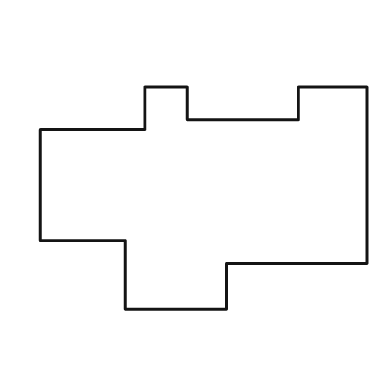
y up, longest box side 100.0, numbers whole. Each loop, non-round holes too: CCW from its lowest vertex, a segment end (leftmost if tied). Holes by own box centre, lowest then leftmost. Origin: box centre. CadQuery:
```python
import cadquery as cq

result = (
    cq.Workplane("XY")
    .moveTo(-24.0, -34.0)
    .lineTo(7.0, -34.0)
    .lineTo(7.0, -20.0)
    .lineTo(50.0, -20.0)
    .lineTo(50.0, 34.0)
    .lineTo(29.0, 34.0)
    .lineTo(29.0, 24.0)
    .lineTo(-5.0, 24.0)
    .lineTo(-5.0, 34.0)
    .lineTo(-18.0, 34.0)
    .lineTo(-18.0, 21.0)
    .lineTo(-50.0, 21.0)
    .lineTo(-50.0, -13.0)
    .lineTo(-24.0, -13.0)
    .close()
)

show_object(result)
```